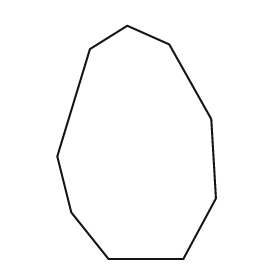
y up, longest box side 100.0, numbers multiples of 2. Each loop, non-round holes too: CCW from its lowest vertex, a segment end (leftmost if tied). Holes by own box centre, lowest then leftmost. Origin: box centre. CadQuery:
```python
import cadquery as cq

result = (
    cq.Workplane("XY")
    .moveTo(-12.0, -50.0)
    .lineTo(20.0, -50.0)
    .lineTo(34.0, -24.0)
    .lineTo(32.0, 10.0)
    .lineTo(14.0, 42.0)
    .lineTo(-4.0, 50.0)
    .lineTo(-20.0, 40.0)
    .lineTo(-34.0, -6.0)
    .lineTo(-28.0, -30.0)
    .close()
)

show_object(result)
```